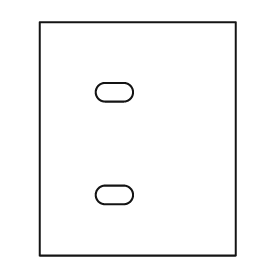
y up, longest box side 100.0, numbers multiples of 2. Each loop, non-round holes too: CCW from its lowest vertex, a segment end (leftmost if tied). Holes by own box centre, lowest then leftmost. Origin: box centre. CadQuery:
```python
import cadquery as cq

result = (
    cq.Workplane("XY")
    .moveTo(-42.0, -50.0)
    .lineTo(42.0, -50.0)
    .lineTo(42.0, 50.0)
    .lineTo(-42.0, 50.0)
    .close()
    .moveTo(-14.0, -28.0)
    .lineTo(-6.0, -28.0)
    .threePointArc((-2.0, -24.0), (-6.0, -20.0))
    .lineTo(-14.0, -20.0)
    .threePointArc((-18.0, -24.0), (-14.0, -28.0))
    .close()
    .moveTo(-14.0, 16.0)
    .lineTo(-6.0, 16.0)
    .threePointArc((-2.0, 20.0), (-6.0, 24.0))
    .lineTo(-14.0, 24.0)
    .threePointArc((-18.0, 20.0), (-14.0, 16.0))
    .close()
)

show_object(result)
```